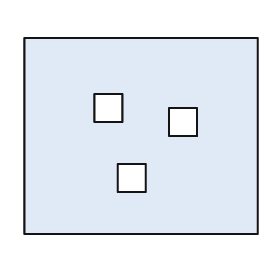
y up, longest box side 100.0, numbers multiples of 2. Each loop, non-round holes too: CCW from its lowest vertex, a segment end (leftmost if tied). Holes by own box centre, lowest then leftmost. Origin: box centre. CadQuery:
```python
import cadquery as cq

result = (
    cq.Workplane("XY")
    .moveTo(-50.0, -42.0)
    .lineTo(50.0, -42.0)
    .lineTo(50.0, 42.0)
    .lineTo(-50.0, 42.0)
    .close()
    .moveTo(-10.0, -24.0)
    .lineTo(2.0, -24.0)
    .lineTo(2.0, -12.0)
    .lineTo(-10.0, -12.0)
    .close()
    .moveTo(12.0, 0.0)
    .lineTo(24.0, 0.0)
    .lineTo(24.0, 12.0)
    .lineTo(12.0, 12.0)
    .close()
    .moveTo(-20.0, 6.0)
    .lineTo(-8.0, 6.0)
    .lineTo(-8.0, 18.0)
    .lineTo(-20.0, 18.0)
    .close()
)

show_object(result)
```